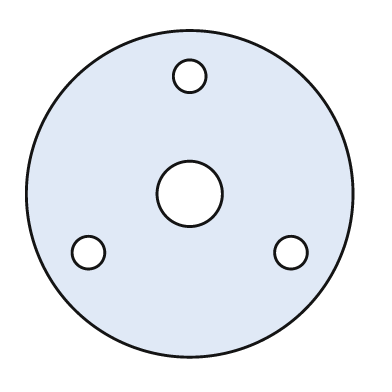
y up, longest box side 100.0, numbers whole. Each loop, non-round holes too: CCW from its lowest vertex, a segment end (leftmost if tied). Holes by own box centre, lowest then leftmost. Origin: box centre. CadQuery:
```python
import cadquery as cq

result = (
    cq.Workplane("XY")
    .moveTo(0.0, 0.0)
    .circle(50.0)
    .moveTo(-31.0, -18.0)
    .circle(5.0)
    .moveTo(31.0, -18.0)
    .circle(5.0)
    .moveTo(0.0, 0.0)
    .circle(10.0)
    .moveTo(0.0, 36.0)
    .circle(5.0)
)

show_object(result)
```